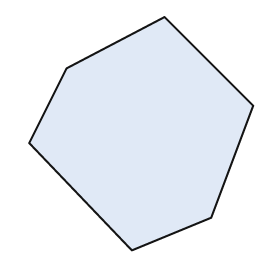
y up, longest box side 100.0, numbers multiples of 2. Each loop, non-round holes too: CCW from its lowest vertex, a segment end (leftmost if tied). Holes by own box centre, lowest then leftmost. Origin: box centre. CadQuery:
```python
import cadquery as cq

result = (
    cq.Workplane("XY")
    .moveTo(-4.0, -50.0)
    .lineTo(30.0, -36.0)
    .lineTo(48.0, 12.0)
    .lineTo(10.0, 50.0)
    .lineTo(-32.0, 28.0)
    .lineTo(-48.0, -4.0)
    .close()
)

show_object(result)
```